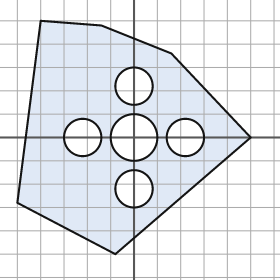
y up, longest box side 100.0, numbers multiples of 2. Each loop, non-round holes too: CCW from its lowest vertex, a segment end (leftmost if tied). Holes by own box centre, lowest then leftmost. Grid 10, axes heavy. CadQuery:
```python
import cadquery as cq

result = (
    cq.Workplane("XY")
    .moveTo(-8.0, -50.0)
    .lineTo(50.0, 0.0)
    .lineTo(16.0, 36.0)
    .lineTo(-14.0, 48.0)
    .lineTo(-40.0, 50.0)
    .lineTo(-50.0, -28.0)
    .close()
    .moveTo(0.0, -22.0)
    .circle(8.0)
    .moveTo(-22.0, 0.0)
    .circle(8.0)
    .moveTo(0.0, 0.0)
    .circle(10.0)
    .moveTo(22.0, 0.0)
    .circle(8.0)
    .moveTo(0.0, 22.0)
    .circle(8.0)
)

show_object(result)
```